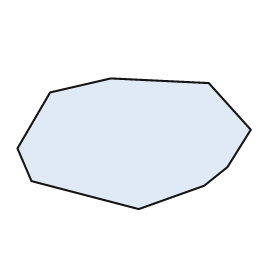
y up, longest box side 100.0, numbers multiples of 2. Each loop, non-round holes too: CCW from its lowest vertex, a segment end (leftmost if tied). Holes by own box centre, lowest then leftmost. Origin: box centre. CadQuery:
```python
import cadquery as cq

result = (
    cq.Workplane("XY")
    .moveTo(2.0, -28.0)
    .lineTo(30.0, -18.0)
    .lineTo(40.0, -10.0)
    .lineTo(50.0, 6.0)
    .lineTo(32.0, 26.0)
    .lineTo(-10.0, 28.0)
    .lineTo(-36.0, 22.0)
    .lineTo(-50.0, -2.0)
    .lineTo(-44.0, -16.0)
    .close()
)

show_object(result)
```